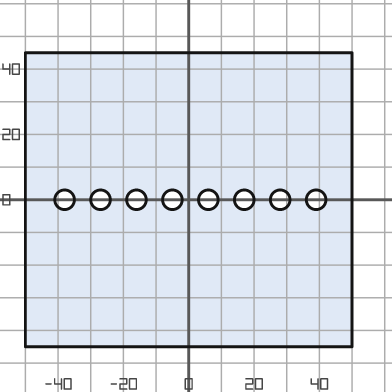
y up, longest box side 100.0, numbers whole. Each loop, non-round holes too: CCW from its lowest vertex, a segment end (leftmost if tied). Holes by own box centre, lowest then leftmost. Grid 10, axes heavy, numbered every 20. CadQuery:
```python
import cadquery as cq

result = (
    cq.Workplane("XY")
    .moveTo(-50.0, -45.0)
    .lineTo(50.0, -45.0)
    .lineTo(50.0, 45.0)
    .lineTo(-50.0, 45.0)
    .close()
    .moveTo(-38.0, 0.0)
    .circle(3.0)
    .moveTo(-27.0, 0.0)
    .circle(3.0)
    .moveTo(-16.0, 0.0)
    .circle(3.0)
    .moveTo(-5.0, 0.0)
    .circle(3.0)
    .moveTo(6.0, 0.0)
    .circle(3.0)
    .moveTo(17.0, 0.0)
    .circle(3.0)
    .moveTo(28.0, 0.0)
    .circle(3.0)
    .moveTo(39.0, 0.0)
    .circle(3.0)
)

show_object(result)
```